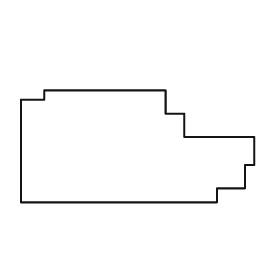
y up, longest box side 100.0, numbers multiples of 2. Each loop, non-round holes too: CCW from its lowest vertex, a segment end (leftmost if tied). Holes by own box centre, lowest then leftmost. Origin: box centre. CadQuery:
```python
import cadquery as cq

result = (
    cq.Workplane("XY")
    .moveTo(-50.0, -24.0)
    .lineTo(34.0, -24.0)
    .lineTo(34.0, -18.0)
    .lineTo(46.0, -18.0)
    .lineTo(46.0, -8.0)
    .lineTo(50.0, -8.0)
    .lineTo(50.0, 4.0)
    .lineTo(20.0, 4.0)
    .lineTo(20.0, 14.0)
    .lineTo(12.0, 14.0)
    .lineTo(12.0, 24.0)
    .lineTo(-40.0, 24.0)
    .lineTo(-40.0, 20.0)
    .lineTo(-50.0, 20.0)
    .close()
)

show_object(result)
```